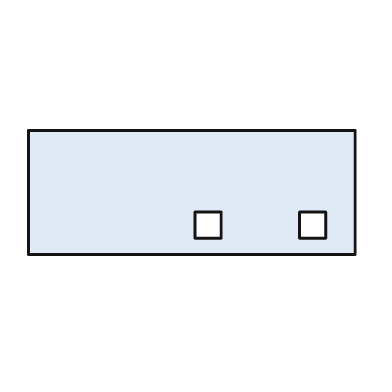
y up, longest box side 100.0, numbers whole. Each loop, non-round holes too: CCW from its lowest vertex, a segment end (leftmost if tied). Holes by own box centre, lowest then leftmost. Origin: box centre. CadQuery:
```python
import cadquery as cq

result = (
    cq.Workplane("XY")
    .moveTo(-50.0, -19.0)
    .lineTo(50.0, -19.0)
    .lineTo(50.0, 19.0)
    .lineTo(-50.0, 19.0)
    .close()
    .moveTo(1.0, -14.0)
    .lineTo(9.0, -14.0)
    .lineTo(9.0, -6.0)
    .lineTo(1.0, -6.0)
    .close()
    .moveTo(33.0, -14.0)
    .lineTo(41.0, -14.0)
    .lineTo(41.0, -6.0)
    .lineTo(33.0, -6.0)
    .close()
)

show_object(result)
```